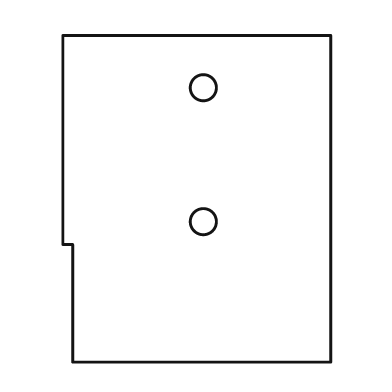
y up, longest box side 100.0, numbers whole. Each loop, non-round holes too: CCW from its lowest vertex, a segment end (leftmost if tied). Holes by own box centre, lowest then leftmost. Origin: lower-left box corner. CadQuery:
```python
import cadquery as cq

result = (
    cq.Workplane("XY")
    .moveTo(3.0, 0.0)
    .lineTo(82.0, 0.0)
    .lineTo(82.0, 100.0)
    .lineTo(0.0, 100.0)
    .lineTo(0.0, 36.0)
    .lineTo(3.0, 36.0)
    .close()
    .moveTo(43.0, 43.0)
    .circle(4.0)
    .moveTo(43.0, 84.0)
    .circle(4.0)
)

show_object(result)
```